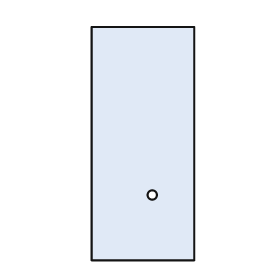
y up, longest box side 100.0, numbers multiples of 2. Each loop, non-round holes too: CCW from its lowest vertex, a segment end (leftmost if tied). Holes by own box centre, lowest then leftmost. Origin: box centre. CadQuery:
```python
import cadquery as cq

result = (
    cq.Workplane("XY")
    .moveTo(-22.0, -50.0)
    .lineTo(22.0, -50.0)
    .lineTo(22.0, 50.0)
    .lineTo(-22.0, 50.0)
    .close()
    .moveTo(4.0, -22.0)
    .circle(2.0)
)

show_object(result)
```